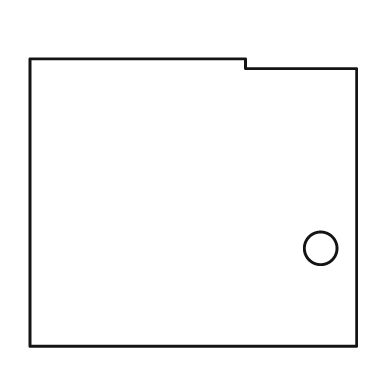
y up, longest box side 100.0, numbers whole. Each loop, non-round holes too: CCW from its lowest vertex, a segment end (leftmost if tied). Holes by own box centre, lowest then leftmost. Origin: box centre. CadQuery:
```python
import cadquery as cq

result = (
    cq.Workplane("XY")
    .moveTo(-50.0, -44.0)
    .lineTo(50.0, -44.0)
    .lineTo(50.0, 41.0)
    .lineTo(16.0, 41.0)
    .lineTo(16.0, 44.0)
    .lineTo(-50.0, 44.0)
    .close()
    .moveTo(39.0, -14.0)
    .circle(5.0)
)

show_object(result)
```